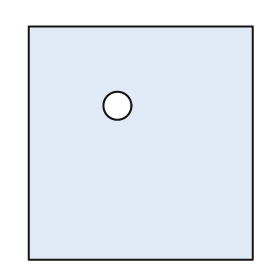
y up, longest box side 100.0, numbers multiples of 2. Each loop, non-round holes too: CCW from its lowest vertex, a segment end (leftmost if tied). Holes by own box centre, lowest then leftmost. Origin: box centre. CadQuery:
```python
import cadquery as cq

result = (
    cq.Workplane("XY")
    .moveTo(-48.0, -50.0)
    .lineTo(48.0, -50.0)
    .lineTo(48.0, 50.0)
    .lineTo(-48.0, 50.0)
    .close()
    .moveTo(-10.0, 16.0)
    .circle(6.0)
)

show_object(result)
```